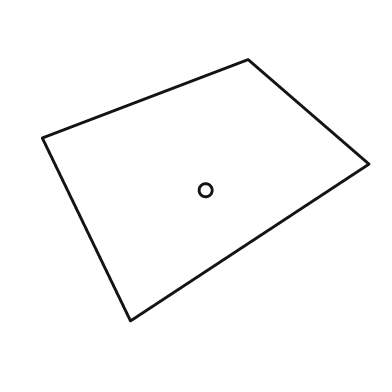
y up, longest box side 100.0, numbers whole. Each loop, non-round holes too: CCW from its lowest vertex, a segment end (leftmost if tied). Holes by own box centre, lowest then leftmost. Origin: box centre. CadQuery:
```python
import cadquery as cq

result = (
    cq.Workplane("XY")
    .moveTo(-23.0, -40.0)
    .lineTo(50.0, 8.0)
    .lineTo(13.0, 40.0)
    .lineTo(-50.0, 16.0)
    .close()
    .moveTo(0.0, 0.0)
    .circle(2.0)
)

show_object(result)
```